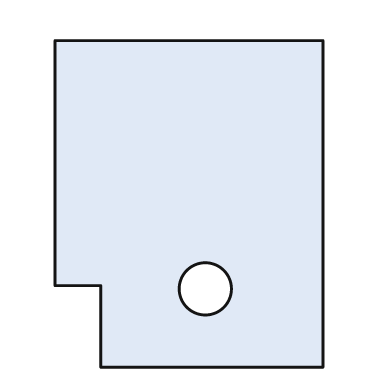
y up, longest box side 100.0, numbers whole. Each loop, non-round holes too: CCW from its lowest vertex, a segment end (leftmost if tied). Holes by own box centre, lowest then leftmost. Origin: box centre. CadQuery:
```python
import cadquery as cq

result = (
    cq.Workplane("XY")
    .moveTo(-27.0, -50.0)
    .lineTo(41.0, -50.0)
    .lineTo(41.0, 50.0)
    .lineTo(-41.0, 50.0)
    .lineTo(-41.0, -25.0)
    .lineTo(-27.0, -25.0)
    .close()
    .moveTo(5.0, -26.0)
    .circle(8.0)
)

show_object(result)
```